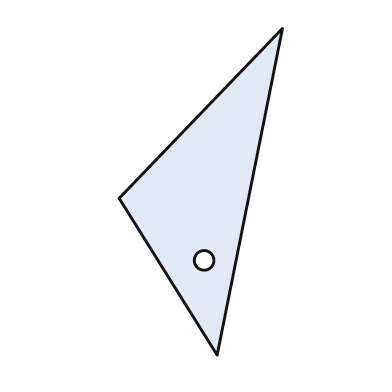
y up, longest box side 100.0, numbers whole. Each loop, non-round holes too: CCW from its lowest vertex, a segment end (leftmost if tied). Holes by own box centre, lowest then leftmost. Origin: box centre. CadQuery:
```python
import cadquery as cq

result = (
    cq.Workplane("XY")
    .moveTo(5.0, -50.0)
    .lineTo(25.0, 50.0)
    .lineTo(-25.0, -2.0)
    .close()
    .moveTo(1.0, -21.0)
    .circle(3.0)
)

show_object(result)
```